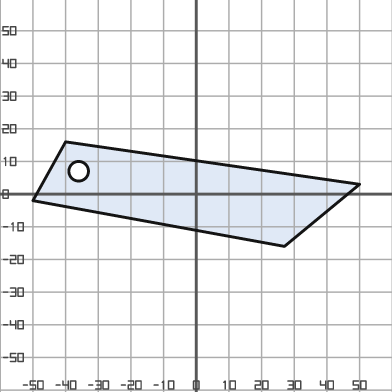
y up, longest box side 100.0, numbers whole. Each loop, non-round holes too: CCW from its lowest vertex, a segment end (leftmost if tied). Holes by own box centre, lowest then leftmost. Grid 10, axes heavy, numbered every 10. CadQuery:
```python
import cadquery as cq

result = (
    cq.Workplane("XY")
    .moveTo(27.0, -16.0)
    .lineTo(50.0, 3.0)
    .lineTo(-40.0, 16.0)
    .lineTo(-50.0, -2.0)
    .close()
    .moveTo(-36.0, 7.0)
    .circle(3.0)
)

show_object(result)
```